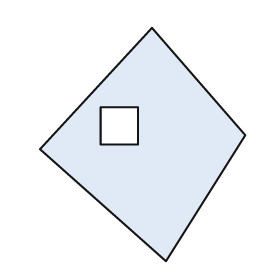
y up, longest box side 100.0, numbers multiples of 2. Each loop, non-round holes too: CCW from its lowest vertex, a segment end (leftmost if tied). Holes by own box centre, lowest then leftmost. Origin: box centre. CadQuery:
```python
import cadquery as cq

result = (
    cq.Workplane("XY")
    .moveTo(10.0, -50.0)
    .lineTo(44.0, 4.0)
    .lineTo(4.0, 50.0)
    .lineTo(-44.0, -2.0)
    .close()
    .moveTo(-18.0, 0.0)
    .lineTo(-2.0, 0.0)
    .lineTo(-2.0, 16.0)
    .lineTo(-18.0, 16.0)
    .close()
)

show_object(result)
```